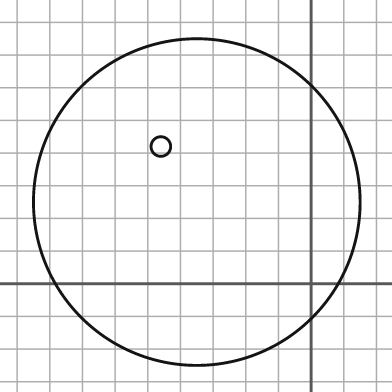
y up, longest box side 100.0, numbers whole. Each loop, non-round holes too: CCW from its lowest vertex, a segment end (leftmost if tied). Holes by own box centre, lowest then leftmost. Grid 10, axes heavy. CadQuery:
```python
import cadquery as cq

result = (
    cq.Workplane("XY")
    .moveTo(-35.0, 25.0)
    .circle(50.0)
    .moveTo(-46.0, 42.0)
    .circle(3.0)
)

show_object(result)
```